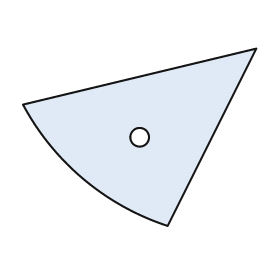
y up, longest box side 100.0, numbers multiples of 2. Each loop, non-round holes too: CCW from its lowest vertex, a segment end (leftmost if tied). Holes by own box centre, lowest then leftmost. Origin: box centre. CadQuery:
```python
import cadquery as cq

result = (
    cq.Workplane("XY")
    .moveTo(12.0, -38.0)
    .lineTo(50.0, 38.0)
    .lineTo(-50.0, 14.0)
    .threePointArc((-24.0, -18.0), (12.0, -38.0))
    .close()
    .moveTo(0.0, 0.0)
    .circle(4.0)
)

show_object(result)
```